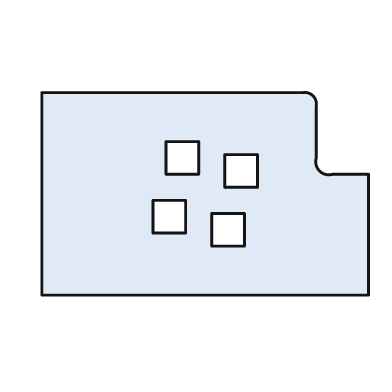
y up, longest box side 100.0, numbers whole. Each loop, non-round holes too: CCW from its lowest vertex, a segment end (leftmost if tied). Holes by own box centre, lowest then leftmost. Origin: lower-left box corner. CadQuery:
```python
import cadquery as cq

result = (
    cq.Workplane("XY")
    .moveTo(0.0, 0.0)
    .lineTo(100.0, 0.0)
    .lineTo(100.0, 37.0)
    .lineTo(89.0, 37.0)
    .threePointArc((85.0, 38.0), (84.0, 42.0))
    .lineTo(84.0, 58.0)
    .threePointArc((83.0, 61.0), (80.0, 62.0))
    .lineTo(0.0, 62.0)
    .close()
    .moveTo(52.0, 15.0)
    .lineTo(62.0, 15.0)
    .lineTo(62.0, 25.0)
    .lineTo(52.0, 25.0)
    .close()
    .moveTo(34.0, 19.0)
    .lineTo(44.0, 19.0)
    .lineTo(44.0, 29.0)
    .lineTo(34.0, 29.0)
    .close()
    .moveTo(56.0, 33.0)
    .lineTo(66.0, 33.0)
    .lineTo(66.0, 43.0)
    .lineTo(56.0, 43.0)
    .close()
    .moveTo(38.0, 37.0)
    .lineTo(48.0, 37.0)
    .lineTo(48.0, 47.0)
    .lineTo(38.0, 47.0)
    .close()
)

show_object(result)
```